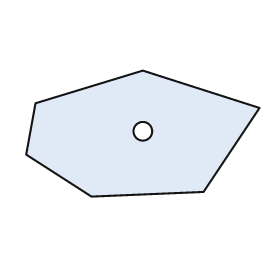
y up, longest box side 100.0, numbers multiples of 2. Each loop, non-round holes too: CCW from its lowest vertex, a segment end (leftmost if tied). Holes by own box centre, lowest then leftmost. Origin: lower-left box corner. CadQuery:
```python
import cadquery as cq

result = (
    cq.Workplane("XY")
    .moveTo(28.0, 0.0)
    .lineTo(76.0, 2.0)
    .lineTo(100.0, 38.0)
    .lineTo(50.0, 54.0)
    .lineTo(4.0, 40.0)
    .lineTo(0.0, 18.0)
    .close()
    .moveTo(50.0, 28.0)
    .circle(4.0)
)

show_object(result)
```